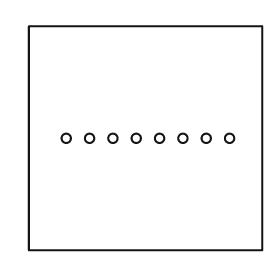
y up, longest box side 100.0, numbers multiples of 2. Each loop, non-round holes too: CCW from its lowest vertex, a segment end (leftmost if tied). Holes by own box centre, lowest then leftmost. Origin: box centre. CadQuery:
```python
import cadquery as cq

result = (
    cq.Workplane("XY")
    .moveTo(-50.0, -48.0)
    .lineTo(50.0, -48.0)
    .lineTo(50.0, 48.0)
    .lineTo(-50.0, 48.0)
    .close()
    .moveTo(-34.0, 0.0)
    .circle(2.0)
    .moveTo(-24.0, 0.0)
    .circle(2.0)
    .moveTo(-14.0, 0.0)
    .circle(2.0)
    .moveTo(-4.0, 0.0)
    .circle(2.0)
    .moveTo(6.0, 0.0)
    .circle(2.0)
    .moveTo(16.0, 0.0)
    .circle(2.0)
    .moveTo(26.0, 0.0)
    .circle(2.0)
    .moveTo(36.0, 0.0)
    .circle(2.0)
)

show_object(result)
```